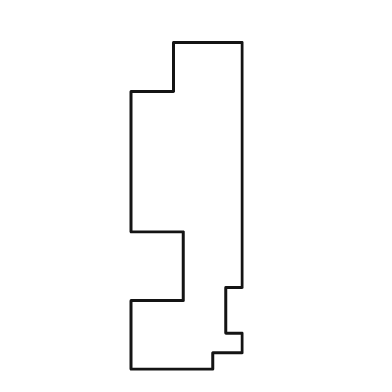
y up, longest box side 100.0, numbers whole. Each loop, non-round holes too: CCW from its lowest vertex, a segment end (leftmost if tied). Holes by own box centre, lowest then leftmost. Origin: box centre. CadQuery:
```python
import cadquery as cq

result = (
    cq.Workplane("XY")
    .moveTo(-17.0, -50.0)
    .lineTo(8.0, -50.0)
    .lineTo(8.0, -45.0)
    .lineTo(17.0, -45.0)
    .lineTo(17.0, -39.0)
    .lineTo(12.0, -39.0)
    .lineTo(12.0, -25.0)
    .lineTo(17.0, -25.0)
    .lineTo(17.0, 50.0)
    .lineTo(-4.0, 50.0)
    .lineTo(-4.0, 35.0)
    .lineTo(-17.0, 35.0)
    .lineTo(-17.0, -8.0)
    .lineTo(-1.0, -8.0)
    .lineTo(-1.0, -29.0)
    .lineTo(-17.0, -29.0)
    .close()
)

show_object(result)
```